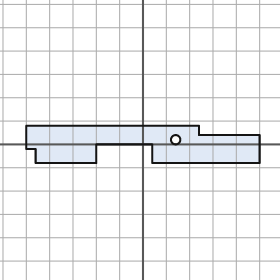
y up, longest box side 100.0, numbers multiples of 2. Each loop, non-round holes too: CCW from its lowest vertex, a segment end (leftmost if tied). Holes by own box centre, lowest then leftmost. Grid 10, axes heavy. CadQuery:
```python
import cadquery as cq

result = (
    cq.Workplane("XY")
    .moveTo(-46.0, -8.0)
    .lineTo(-20.0, -8.0)
    .lineTo(-20.0, 0.0)
    .lineTo(4.0, 0.0)
    .lineTo(4.0, -8.0)
    .lineTo(50.0, -8.0)
    .lineTo(50.0, 4.0)
    .lineTo(24.0, 4.0)
    .lineTo(24.0, 8.0)
    .lineTo(-50.0, 8.0)
    .lineTo(-50.0, -2.0)
    .lineTo(-46.0, -2.0)
    .close()
    .moveTo(14.0, 2.0)
    .circle(2.0)
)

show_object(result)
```